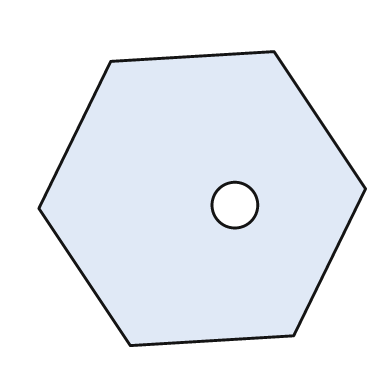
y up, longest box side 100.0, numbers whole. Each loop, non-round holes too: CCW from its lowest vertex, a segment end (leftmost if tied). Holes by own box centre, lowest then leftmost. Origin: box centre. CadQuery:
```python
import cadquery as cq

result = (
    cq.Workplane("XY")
    .moveTo(-22.0, -45.0)
    .lineTo(28.0, -42.0)
    .lineTo(50.0, 3.0)
    .lineTo(22.0, 45.0)
    .lineTo(-28.0, 42.0)
    .lineTo(-50.0, -3.0)
    .close()
    .moveTo(10.0, -2.0)
    .circle(7.0)
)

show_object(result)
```